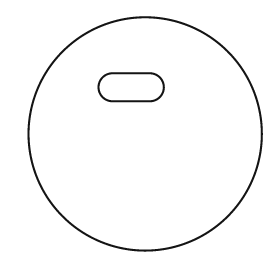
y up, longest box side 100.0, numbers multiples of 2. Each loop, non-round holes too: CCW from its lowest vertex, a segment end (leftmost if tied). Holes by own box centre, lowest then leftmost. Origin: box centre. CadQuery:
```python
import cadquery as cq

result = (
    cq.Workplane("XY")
    .moveTo(0.0, 0.0)
    .circle(50.0)
    .moveTo(-14.0, 14.0)
    .lineTo(2.0, 14.0)
    .threePointArc((8.0, 20.0), (2.0, 26.0))
    .lineTo(-14.0, 26.0)
    .threePointArc((-20.0, 20.0), (-14.0, 14.0))
    .close()
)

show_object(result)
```